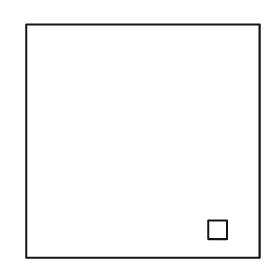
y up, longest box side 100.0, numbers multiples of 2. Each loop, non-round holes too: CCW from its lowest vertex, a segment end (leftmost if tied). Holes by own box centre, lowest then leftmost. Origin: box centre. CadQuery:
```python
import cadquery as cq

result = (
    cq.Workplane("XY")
    .moveTo(-50.0, -50.0)
    .lineTo(50.0, -50.0)
    .lineTo(50.0, 50.0)
    .lineTo(-50.0, 50.0)
    .close()
    .moveTo(28.0, -42.0)
    .lineTo(36.0, -42.0)
    .lineTo(36.0, -34.0)
    .lineTo(28.0, -34.0)
    .close()
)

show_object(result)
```